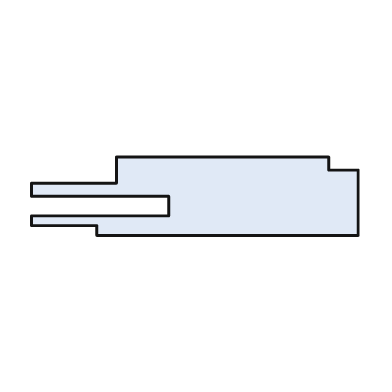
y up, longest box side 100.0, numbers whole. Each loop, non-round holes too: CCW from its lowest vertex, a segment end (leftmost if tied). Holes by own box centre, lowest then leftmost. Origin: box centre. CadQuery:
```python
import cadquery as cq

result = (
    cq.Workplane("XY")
    .moveTo(-30.0, -12.0)
    .lineTo(50.0, -12.0)
    .lineTo(50.0, 8.0)
    .lineTo(41.0, 8.0)
    .lineTo(41.0, 12.0)
    .lineTo(-24.0, 12.0)
    .lineTo(-24.0, 4.0)
    .lineTo(-50.0, 4.0)
    .lineTo(-50.0, 0.0)
    .lineTo(-8.0, 0.0)
    .lineTo(-8.0, -6.0)
    .lineTo(-50.0, -6.0)
    .lineTo(-50.0, -9.0)
    .lineTo(-30.0, -9.0)
    .close()
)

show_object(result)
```